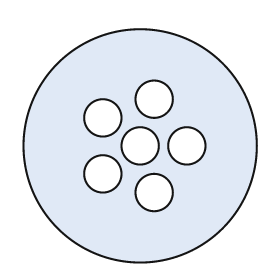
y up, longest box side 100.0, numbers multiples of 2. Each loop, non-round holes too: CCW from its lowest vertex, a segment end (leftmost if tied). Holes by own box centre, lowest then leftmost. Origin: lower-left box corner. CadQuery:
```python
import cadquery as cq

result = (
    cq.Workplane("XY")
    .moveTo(50.0, 50.0)
    .circle(50.0)
    .moveTo(56.0, 30.0)
    .circle(8.0)
    .moveTo(34.0, 38.0)
    .circle(8.0)
    .moveTo(50.0, 50.0)
    .circle(8.0)
    .moveTo(70.0, 50.0)
    .circle(8.0)
    .moveTo(34.0, 62.0)
    .circle(8.0)
    .moveTo(56.0, 70.0)
    .circle(8.0)
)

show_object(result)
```